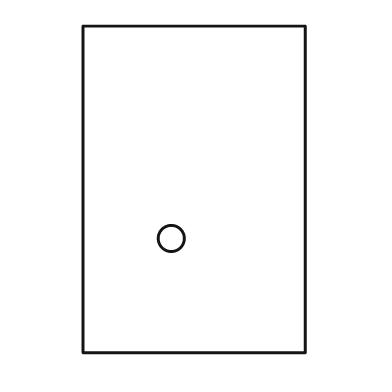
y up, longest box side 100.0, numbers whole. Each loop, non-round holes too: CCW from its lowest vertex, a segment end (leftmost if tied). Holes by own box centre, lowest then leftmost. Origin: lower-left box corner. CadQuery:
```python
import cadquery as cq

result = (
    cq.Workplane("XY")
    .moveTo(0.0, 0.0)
    .lineTo(68.0, 0.0)
    .lineTo(68.0, 100.0)
    .lineTo(0.0, 100.0)
    .close()
    .moveTo(27.0, 35.0)
    .circle(4.0)
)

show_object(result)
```